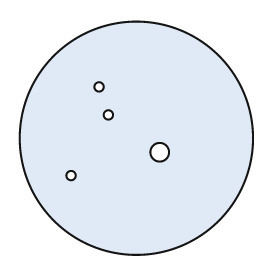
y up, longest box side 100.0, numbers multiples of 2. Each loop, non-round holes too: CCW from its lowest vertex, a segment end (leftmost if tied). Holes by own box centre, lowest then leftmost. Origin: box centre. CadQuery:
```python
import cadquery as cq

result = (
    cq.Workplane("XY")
    .moveTo(0.0, 0.0)
    .circle(50.0)
    .moveTo(-28.0, -16.0)
    .circle(2.0)
    .moveTo(10.0, -6.0)
    .circle(4.0)
    .moveTo(-12.0, 10.0)
    .circle(2.0)
    .moveTo(-16.0, 22.0)
    .circle(2.0)
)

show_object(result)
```